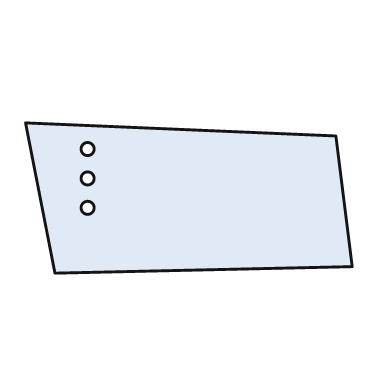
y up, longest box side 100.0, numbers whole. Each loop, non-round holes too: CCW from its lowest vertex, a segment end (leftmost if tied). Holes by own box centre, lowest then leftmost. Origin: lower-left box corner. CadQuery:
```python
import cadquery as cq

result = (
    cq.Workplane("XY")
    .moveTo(9.0, 0.0)
    .lineTo(100.0, 2.0)
    .lineTo(95.0, 42.0)
    .lineTo(0.0, 46.0)
    .close()
    .moveTo(19.0, 20.0)
    .circle(2.0)
    .moveTo(19.0, 29.0)
    .circle(2.0)
    .moveTo(19.0, 38.0)
    .circle(2.0)
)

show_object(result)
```